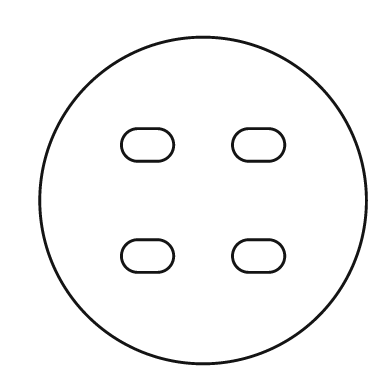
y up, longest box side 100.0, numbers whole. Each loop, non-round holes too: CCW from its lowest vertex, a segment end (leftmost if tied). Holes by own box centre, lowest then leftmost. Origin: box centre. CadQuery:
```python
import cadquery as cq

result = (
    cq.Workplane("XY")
    .moveTo(0.0, 0.0)
    .circle(50.0)
    .moveTo(-20.0, -22.0)
    .lineTo(-14.0, -22.0)
    .threePointArc((-9.0, -17.0), (-14.0, -12.0))
    .lineTo(-20.0, -12.0)
    .threePointArc((-25.0, -17.0), (-20.0, -22.0))
    .close()
    .moveTo(14.0, -22.0)
    .lineTo(20.0, -22.0)
    .threePointArc((25.0, -17.0), (20.0, -12.0))
    .lineTo(14.0, -12.0)
    .threePointArc((9.0, -17.0), (14.0, -22.0))
    .close()
    .moveTo(-20.0, 12.0)
    .lineTo(-14.0, 12.0)
    .threePointArc((-9.0, 17.0), (-14.0, 22.0))
    .lineTo(-20.0, 22.0)
    .threePointArc((-25.0, 17.0), (-20.0, 12.0))
    .close()
    .moveTo(14.0, 12.0)
    .lineTo(20.0, 12.0)
    .threePointArc((25.0, 17.0), (20.0, 22.0))
    .lineTo(14.0, 22.0)
    .threePointArc((9.0, 17.0), (14.0, 12.0))
    .close()
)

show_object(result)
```